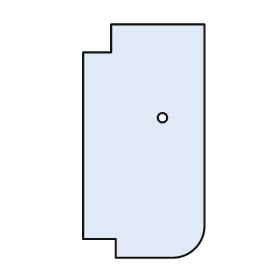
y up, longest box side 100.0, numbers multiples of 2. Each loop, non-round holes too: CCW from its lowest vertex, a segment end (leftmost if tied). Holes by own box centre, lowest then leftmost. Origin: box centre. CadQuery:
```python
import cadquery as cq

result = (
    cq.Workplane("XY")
    .moveTo(-12.0, -50.0)
    .lineTo(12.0, -50.0)
    .threePointArc((22.0, -46.0), (26.0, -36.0))
    .lineTo(26.0, 50.0)
    .lineTo(-14.0, 50.0)
    .lineTo(-14.0, 38.0)
    .lineTo(-26.0, 38.0)
    .lineTo(-26.0, -42.0)
    .lineTo(-12.0, -42.0)
    .close()
    .moveTo(8.0, 10.0)
    .circle(2.0)
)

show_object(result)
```